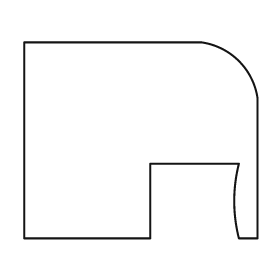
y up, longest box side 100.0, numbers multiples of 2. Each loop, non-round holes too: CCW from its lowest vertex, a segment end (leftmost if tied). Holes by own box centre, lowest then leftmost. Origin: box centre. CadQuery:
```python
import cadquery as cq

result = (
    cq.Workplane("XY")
    .moveTo(-50.0, -42.0)
    .lineTo(4.0, -42.0)
    .lineTo(4.0, -10.0)
    .lineTo(42.0, -10.0)
    .threePointArc((40.0, -26.0), (42.0, -42.0))
    .lineTo(50.0, -42.0)
    .lineTo(50.0, 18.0)
    .threePointArc((42.0, 34.0), (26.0, 42.0))
    .lineTo(-50.0, 42.0)
    .close()
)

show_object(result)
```